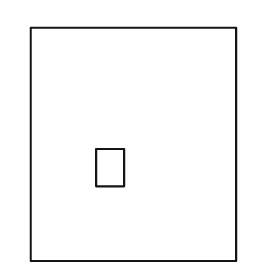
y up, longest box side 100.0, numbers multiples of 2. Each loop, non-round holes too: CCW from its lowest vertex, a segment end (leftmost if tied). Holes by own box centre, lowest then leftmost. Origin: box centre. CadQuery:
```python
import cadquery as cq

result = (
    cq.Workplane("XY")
    .moveTo(-44.0, -50.0)
    .lineTo(44.0, -50.0)
    .lineTo(44.0, 50.0)
    .lineTo(-44.0, 50.0)
    .close()
    .moveTo(-16.0, -18.0)
    .lineTo(-4.0, -18.0)
    .lineTo(-4.0, -2.0)
    .lineTo(-16.0, -2.0)
    .close()
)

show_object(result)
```